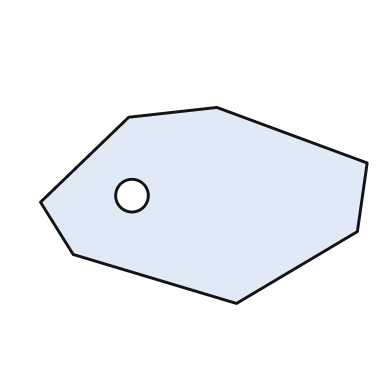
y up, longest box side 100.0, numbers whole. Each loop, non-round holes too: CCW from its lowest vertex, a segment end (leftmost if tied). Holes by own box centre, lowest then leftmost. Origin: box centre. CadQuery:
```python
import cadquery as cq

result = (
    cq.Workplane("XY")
    .moveTo(10.0, -30.0)
    .lineTo(47.0, -8.0)
    .lineTo(50.0, 13.0)
    .lineTo(4.0, 30.0)
    .lineTo(-23.0, 27.0)
    .lineTo(-50.0, 1.0)
    .lineTo(-40.0, -15.0)
    .close()
    .moveTo(-22.0, 3.0)
    .circle(5.0)
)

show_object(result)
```